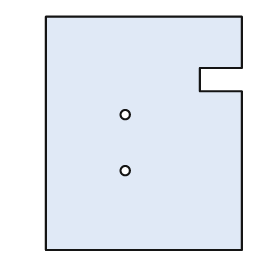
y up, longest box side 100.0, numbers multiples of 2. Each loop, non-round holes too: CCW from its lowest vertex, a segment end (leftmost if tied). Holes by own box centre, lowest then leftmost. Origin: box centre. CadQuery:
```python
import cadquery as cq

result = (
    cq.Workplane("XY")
    .moveTo(-42.0, -50.0)
    .lineTo(42.0, -50.0)
    .lineTo(42.0, 18.0)
    .lineTo(24.0, 18.0)
    .lineTo(24.0, 28.0)
    .lineTo(42.0, 28.0)
    .lineTo(42.0, 50.0)
    .lineTo(-42.0, 50.0)
    .close()
    .moveTo(-8.0, -16.0)
    .circle(2.0)
    .moveTo(-8.0, 8.0)
    .circle(2.0)
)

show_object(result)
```